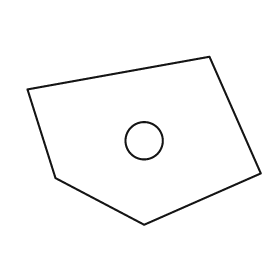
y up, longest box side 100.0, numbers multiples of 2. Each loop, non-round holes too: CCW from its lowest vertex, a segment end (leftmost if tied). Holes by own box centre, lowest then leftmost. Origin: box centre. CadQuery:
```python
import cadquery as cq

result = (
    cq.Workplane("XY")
    .moveTo(0.0, -36.0)
    .lineTo(50.0, -14.0)
    .lineTo(28.0, 36.0)
    .lineTo(-50.0, 22.0)
    .lineTo(-38.0, -16.0)
    .close()
    .moveTo(0.0, 0.0)
    .circle(8.0)
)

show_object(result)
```